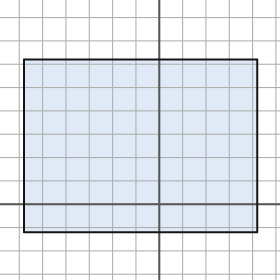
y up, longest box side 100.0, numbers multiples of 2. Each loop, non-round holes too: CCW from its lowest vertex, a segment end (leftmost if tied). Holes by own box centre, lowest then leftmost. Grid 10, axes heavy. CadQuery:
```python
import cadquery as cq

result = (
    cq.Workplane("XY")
    .moveTo(-58.0, -12.0)
    .lineTo(42.0, -12.0)
    .lineTo(42.0, 62.0)
    .lineTo(-58.0, 62.0)
    .close()
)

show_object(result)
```